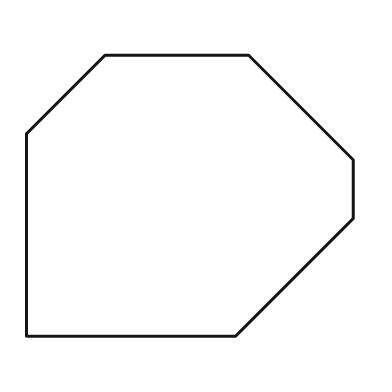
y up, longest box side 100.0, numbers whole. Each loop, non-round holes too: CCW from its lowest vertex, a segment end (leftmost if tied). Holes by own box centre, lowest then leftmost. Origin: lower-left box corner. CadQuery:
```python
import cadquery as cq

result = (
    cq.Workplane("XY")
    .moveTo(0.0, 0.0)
    .lineTo(64.0, 0.0)
    .lineTo(100.0, 36.0)
    .lineTo(100.0, 54.0)
    .lineTo(68.0, 86.0)
    .lineTo(24.0, 86.0)
    .lineTo(0.0, 62.0)
    .close()
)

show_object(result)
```